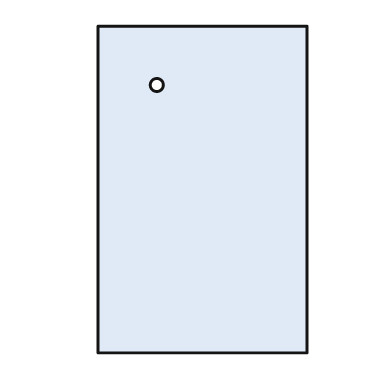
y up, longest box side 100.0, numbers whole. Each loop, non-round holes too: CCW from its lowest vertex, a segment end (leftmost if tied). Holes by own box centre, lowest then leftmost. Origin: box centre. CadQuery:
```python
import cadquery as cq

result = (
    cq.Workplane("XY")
    .moveTo(-32.0, -50.0)
    .lineTo(32.0, -50.0)
    .lineTo(32.0, 50.0)
    .lineTo(-32.0, 50.0)
    .close()
    .moveTo(-14.0, 32.0)
    .circle(2.0)
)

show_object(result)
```